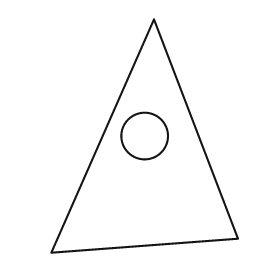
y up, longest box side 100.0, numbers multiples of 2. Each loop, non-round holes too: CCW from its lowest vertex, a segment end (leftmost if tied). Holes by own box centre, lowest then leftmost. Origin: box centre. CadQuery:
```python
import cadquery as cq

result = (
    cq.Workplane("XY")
    .moveTo(-40.0, -50.0)
    .lineTo(40.0, -44.0)
    .lineTo(4.0, 50.0)
    .close()
    .moveTo(0.0, 0.0)
    .circle(10.0)
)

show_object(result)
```